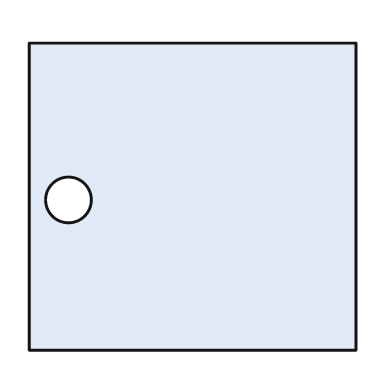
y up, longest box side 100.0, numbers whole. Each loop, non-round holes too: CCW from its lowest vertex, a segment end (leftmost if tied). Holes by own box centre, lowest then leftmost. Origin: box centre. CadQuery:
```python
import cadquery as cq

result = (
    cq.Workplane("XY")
    .moveTo(-50.0, -47.0)
    .lineTo(50.0, -47.0)
    .lineTo(50.0, 47.0)
    .lineTo(-50.0, 47.0)
    .close()
    .moveTo(-38.0, -1.0)
    .circle(7.0)
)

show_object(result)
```